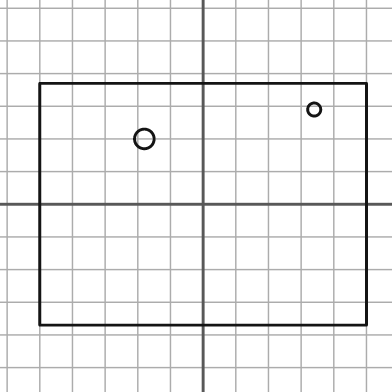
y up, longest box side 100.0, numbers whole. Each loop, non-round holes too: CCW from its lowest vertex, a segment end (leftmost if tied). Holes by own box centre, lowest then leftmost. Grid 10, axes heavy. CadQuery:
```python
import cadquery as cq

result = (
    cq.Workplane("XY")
    .moveTo(-50.0, -37.0)
    .lineTo(50.0, -37.0)
    .lineTo(50.0, 37.0)
    .lineTo(-50.0, 37.0)
    .close()
    .moveTo(-18.0, 20.0)
    .circle(3.0)
    .moveTo(34.0, 29.0)
    .circle(2.0)
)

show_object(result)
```